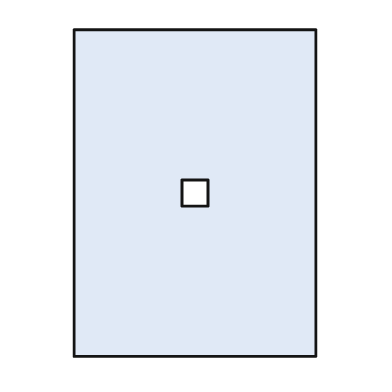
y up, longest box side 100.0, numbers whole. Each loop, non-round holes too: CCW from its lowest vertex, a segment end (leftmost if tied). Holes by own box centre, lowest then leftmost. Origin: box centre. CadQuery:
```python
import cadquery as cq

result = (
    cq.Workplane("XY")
    .moveTo(-37.0, -50.0)
    .lineTo(37.0, -50.0)
    .lineTo(37.0, 50.0)
    .lineTo(-37.0, 50.0)
    .close()
    .moveTo(-4.0, -4.0)
    .lineTo(4.0, -4.0)
    .lineTo(4.0, 4.0)
    .lineTo(-4.0, 4.0)
    .close()
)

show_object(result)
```